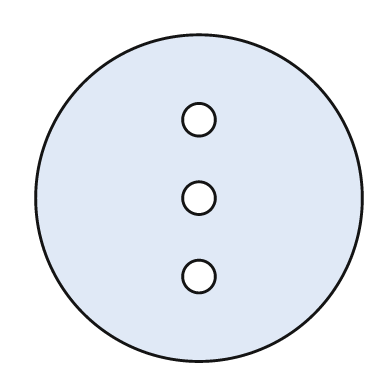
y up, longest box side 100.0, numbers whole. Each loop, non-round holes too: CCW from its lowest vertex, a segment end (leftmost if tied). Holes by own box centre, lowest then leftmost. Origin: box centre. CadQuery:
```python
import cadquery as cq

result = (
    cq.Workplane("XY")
    .moveTo(0.0, 0.0)
    .circle(50.0)
    .moveTo(0.0, -24.0)
    .circle(5.0)
    .moveTo(0.0, 0.0)
    .circle(5.0)
    .moveTo(0.0, 24.0)
    .circle(5.0)
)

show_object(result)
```